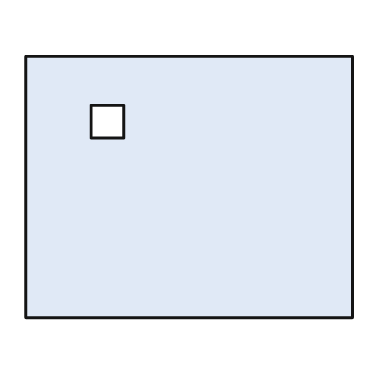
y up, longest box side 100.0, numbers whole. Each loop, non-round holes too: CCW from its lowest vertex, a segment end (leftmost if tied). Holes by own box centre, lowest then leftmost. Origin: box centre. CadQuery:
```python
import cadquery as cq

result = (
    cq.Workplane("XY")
    .moveTo(-50.0, -40.0)
    .lineTo(50.0, -40.0)
    .lineTo(50.0, 40.0)
    .lineTo(-50.0, 40.0)
    .close()
    .moveTo(-30.0, 15.0)
    .lineTo(-20.0, 15.0)
    .lineTo(-20.0, 25.0)
    .lineTo(-30.0, 25.0)
    .close()
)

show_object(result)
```